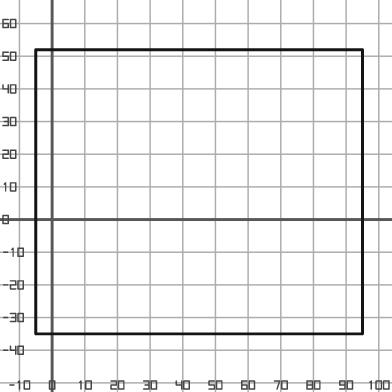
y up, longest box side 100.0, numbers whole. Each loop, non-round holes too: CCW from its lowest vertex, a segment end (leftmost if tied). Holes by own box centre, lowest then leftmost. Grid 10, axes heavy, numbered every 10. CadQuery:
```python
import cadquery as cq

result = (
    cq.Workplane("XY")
    .moveTo(-5.0, -35.0)
    .lineTo(95.0, -35.0)
    .lineTo(95.0, 52.0)
    .lineTo(-5.0, 52.0)
    .close()
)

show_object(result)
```